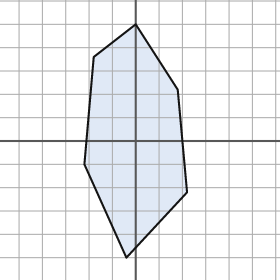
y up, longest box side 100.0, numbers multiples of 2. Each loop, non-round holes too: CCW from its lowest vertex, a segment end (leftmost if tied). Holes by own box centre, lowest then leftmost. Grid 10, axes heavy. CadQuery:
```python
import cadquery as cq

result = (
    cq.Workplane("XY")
    .moveTo(-4.0, -50.0)
    .lineTo(22.0, -22.0)
    .lineTo(18.0, 22.0)
    .lineTo(0.0, 50.0)
    .lineTo(-18.0, 36.0)
    .lineTo(-22.0, -10.0)
    .close()
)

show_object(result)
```